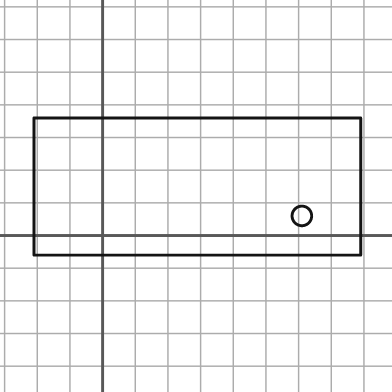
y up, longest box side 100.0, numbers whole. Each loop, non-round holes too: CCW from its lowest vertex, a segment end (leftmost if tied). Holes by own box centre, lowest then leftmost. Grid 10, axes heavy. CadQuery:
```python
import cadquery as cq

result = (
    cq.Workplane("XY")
    .moveTo(-21.0, -6.0)
    .lineTo(79.0, -6.0)
    .lineTo(79.0, 36.0)
    .lineTo(-21.0, 36.0)
    .close()
    .moveTo(61.0, 6.0)
    .circle(3.0)
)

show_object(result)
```